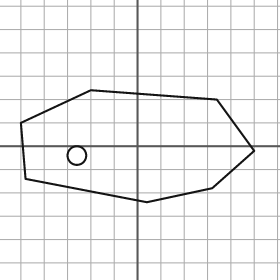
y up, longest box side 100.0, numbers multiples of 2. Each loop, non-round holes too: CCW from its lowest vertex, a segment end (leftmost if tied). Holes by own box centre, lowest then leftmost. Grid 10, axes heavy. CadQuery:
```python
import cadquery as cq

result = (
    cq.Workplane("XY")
    .moveTo(4.0, -24.0)
    .lineTo(32.0, -18.0)
    .lineTo(50.0, -2.0)
    .lineTo(34.0, 20.0)
    .lineTo(-20.0, 24.0)
    .lineTo(-50.0, 10.0)
    .lineTo(-48.0, -14.0)
    .close()
    .moveTo(-26.0, -4.0)
    .circle(4.0)
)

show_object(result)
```